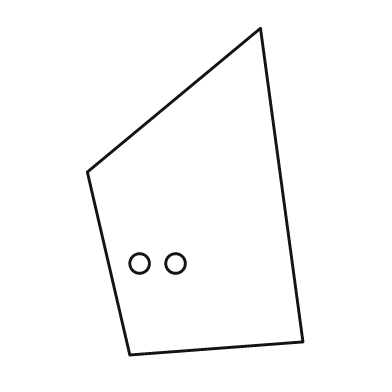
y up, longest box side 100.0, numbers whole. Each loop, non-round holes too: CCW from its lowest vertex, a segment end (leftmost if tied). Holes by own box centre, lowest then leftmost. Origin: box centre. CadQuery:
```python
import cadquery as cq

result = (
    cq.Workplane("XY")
    .moveTo(-20.0, -50.0)
    .lineTo(33.0, -46.0)
    .lineTo(20.0, 50.0)
    .lineTo(-33.0, 6.0)
    .close()
    .moveTo(-17.0, -22.0)
    .circle(3.0)
    .moveTo(-6.0, -22.0)
    .circle(3.0)
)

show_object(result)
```